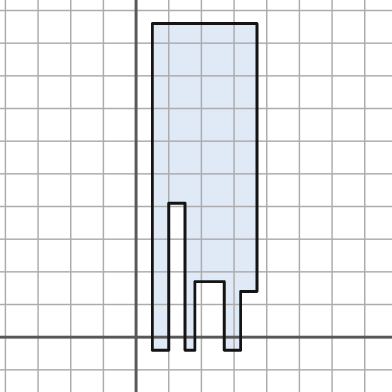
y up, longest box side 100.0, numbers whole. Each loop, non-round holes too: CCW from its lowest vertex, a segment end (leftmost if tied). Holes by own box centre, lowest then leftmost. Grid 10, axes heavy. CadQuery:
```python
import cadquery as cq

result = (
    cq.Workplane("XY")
    .moveTo(5.0, -4.0)
    .lineTo(10.0, -4.0)
    .lineTo(10.0, 41.0)
    .lineTo(15.0, 41.0)
    .lineTo(15.0, -4.0)
    .lineTo(18.0, -4.0)
    .lineTo(18.0, 17.0)
    .lineTo(27.0, 17.0)
    .lineTo(27.0, -4.0)
    .lineTo(32.0, -4.0)
    .lineTo(32.0, 14.0)
    .lineTo(37.0, 14.0)
    .lineTo(37.0, 96.0)
    .lineTo(5.0, 96.0)
    .close()
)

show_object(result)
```